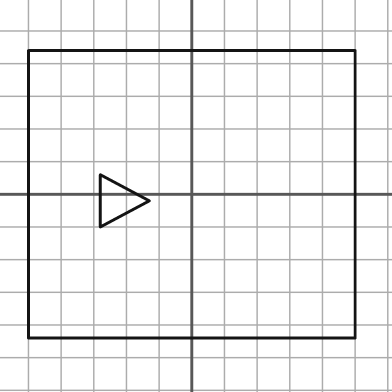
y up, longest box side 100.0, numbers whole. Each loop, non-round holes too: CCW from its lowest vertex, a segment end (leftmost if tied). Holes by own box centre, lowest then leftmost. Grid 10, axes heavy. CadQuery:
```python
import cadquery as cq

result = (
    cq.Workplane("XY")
    .moveTo(-50.0, -44.0)
    .lineTo(50.0, -44.0)
    .lineTo(50.0, 44.0)
    .lineTo(-50.0, 44.0)
    .close()
    .moveTo(-28.0, -10.0)
    .lineTo(-13.0, -2.0)
    .lineTo(-28.0, 6.0)
    .close()
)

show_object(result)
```